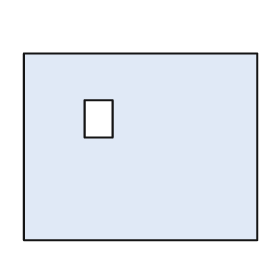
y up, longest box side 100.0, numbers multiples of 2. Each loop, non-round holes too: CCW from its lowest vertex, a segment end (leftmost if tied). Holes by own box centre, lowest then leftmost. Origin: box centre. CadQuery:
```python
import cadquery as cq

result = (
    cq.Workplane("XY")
    .moveTo(-50.0, -40.0)
    .lineTo(50.0, -40.0)
    .lineTo(50.0, 40.0)
    .lineTo(-50.0, 40.0)
    .close()
    .moveTo(-24.0, 4.0)
    .lineTo(-12.0, 4.0)
    .lineTo(-12.0, 20.0)
    .lineTo(-24.0, 20.0)
    .close()
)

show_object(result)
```